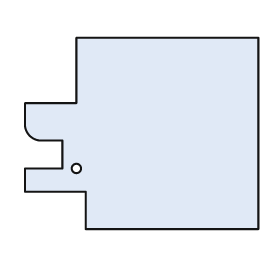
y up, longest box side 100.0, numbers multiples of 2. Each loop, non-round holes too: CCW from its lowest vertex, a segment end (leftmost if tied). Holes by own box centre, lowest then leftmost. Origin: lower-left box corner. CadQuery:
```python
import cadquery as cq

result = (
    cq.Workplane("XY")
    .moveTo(26.0, 0.0)
    .lineTo(100.0, 0.0)
    .lineTo(100.0, 82.0)
    .lineTo(22.0, 82.0)
    .lineTo(22.0, 54.0)
    .lineTo(0.0, 54.0)
    .lineTo(0.0, 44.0)
    .threePointArc((2.0, 40.0), (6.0, 38.0))
    .lineTo(16.0, 38.0)
    .lineTo(16.0, 26.0)
    .lineTo(0.0, 26.0)
    .lineTo(0.0, 16.0)
    .lineTo(26.0, 16.0)
    .close()
    .moveTo(22.0, 26.0)
    .circle(2.0)
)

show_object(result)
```